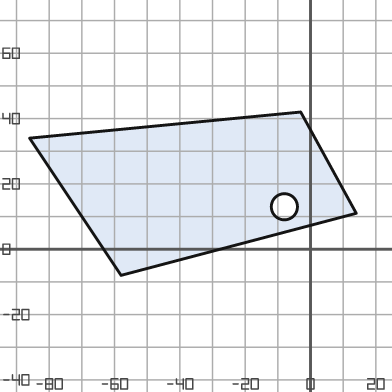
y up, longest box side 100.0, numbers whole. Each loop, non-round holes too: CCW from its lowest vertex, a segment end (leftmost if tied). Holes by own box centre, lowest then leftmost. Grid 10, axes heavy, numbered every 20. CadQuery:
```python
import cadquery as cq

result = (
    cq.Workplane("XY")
    .moveTo(-58.0, -8.0)
    .lineTo(14.0, 11.0)
    .lineTo(-3.0, 42.0)
    .lineTo(-86.0, 34.0)
    .close()
    .moveTo(-8.0, 13.0)
    .circle(4.0)
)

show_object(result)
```